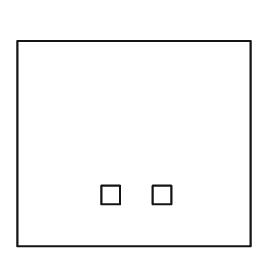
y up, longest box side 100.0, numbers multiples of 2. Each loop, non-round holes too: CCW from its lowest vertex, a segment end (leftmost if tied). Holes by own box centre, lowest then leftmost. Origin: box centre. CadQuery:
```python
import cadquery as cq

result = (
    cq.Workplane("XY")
    .moveTo(-50.0, -44.0)
    .lineTo(50.0, -44.0)
    .lineTo(50.0, 44.0)
    .lineTo(-50.0, 44.0)
    .close()
    .moveTo(-14.0, -26.0)
    .lineTo(-6.0, -26.0)
    .lineTo(-6.0, -18.0)
    .lineTo(-14.0, -18.0)
    .close()
    .moveTo(8.0, -26.0)
    .lineTo(16.0, -26.0)
    .lineTo(16.0, -18.0)
    .lineTo(8.0, -18.0)
    .close()
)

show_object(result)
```